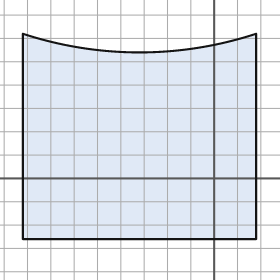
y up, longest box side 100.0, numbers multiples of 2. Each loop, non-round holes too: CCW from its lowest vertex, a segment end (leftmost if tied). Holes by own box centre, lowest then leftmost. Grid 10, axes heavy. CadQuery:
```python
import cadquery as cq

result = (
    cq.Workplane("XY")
    .moveTo(-82.0, -26.0)
    .lineTo(18.0, -26.0)
    .lineTo(18.0, 62.0)
    .threePointArc((-32.0, 54.0), (-82.0, 62.0))
    .close()
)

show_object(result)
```